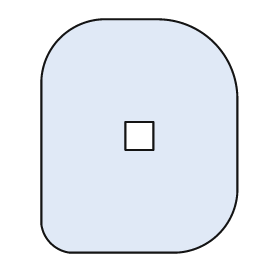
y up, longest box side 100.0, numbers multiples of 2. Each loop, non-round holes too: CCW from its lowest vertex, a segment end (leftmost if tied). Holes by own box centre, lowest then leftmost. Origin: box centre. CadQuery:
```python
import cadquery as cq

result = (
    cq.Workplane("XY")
    .moveTo(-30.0, -50.0)
    .lineTo(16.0, -50.0)
    .threePointArc((34.0, -42.0), (42.0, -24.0))
    .lineTo(42.0, 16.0)
    .threePointArc((32.0, 40.0), (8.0, 50.0))
    .lineTo(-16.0, 50.0)
    .threePointArc((-34.0, 42.0), (-42.0, 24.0))
    .lineTo(-42.0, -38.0)
    .threePointArc((-38.0, -46.0), (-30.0, -50.0))
    .close()
    .moveTo(-6.0, -6.0)
    .lineTo(6.0, -6.0)
    .lineTo(6.0, 6.0)
    .lineTo(-6.0, 6.0)
    .close()
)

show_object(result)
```